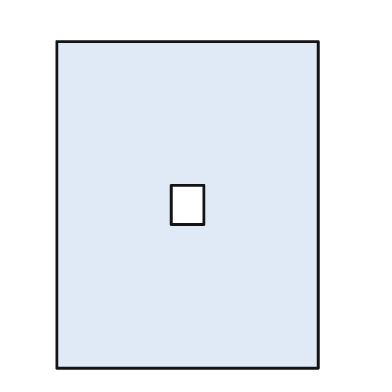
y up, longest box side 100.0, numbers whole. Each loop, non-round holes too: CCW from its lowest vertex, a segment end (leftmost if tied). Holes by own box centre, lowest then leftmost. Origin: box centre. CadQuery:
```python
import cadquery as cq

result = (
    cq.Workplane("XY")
    .moveTo(-40.0, -50.0)
    .lineTo(40.0, -50.0)
    .lineTo(40.0, 50.0)
    .lineTo(-40.0, 50.0)
    .close()
    .moveTo(-5.0, -6.0)
    .lineTo(5.0, -6.0)
    .lineTo(5.0, 6.0)
    .lineTo(-5.0, 6.0)
    .close()
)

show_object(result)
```